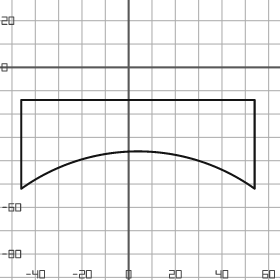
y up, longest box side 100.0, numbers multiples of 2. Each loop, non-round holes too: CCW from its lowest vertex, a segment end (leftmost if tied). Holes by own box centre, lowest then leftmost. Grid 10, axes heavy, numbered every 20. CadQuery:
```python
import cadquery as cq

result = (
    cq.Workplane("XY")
    .moveTo(-46.0, -52.0)
    .threePointArc((4.0, -36.0), (54.0, -52.0))
    .lineTo(54.0, -14.0)
    .lineTo(-46.0, -14.0)
    .close()
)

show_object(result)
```